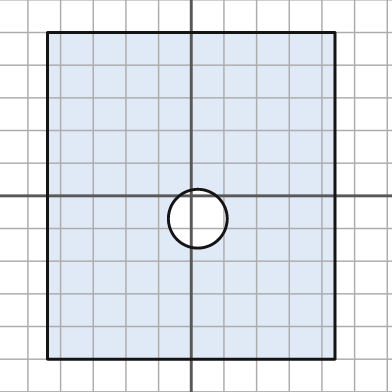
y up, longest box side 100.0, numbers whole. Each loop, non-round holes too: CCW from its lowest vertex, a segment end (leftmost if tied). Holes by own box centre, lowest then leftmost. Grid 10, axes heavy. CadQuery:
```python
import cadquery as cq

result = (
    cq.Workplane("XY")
    .moveTo(-44.0, -50.0)
    .lineTo(44.0, -50.0)
    .lineTo(44.0, 50.0)
    .lineTo(-44.0, 50.0)
    .close()
    .moveTo(2.0, -7.0)
    .circle(9.0)
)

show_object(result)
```